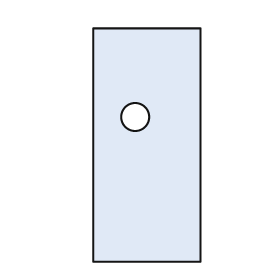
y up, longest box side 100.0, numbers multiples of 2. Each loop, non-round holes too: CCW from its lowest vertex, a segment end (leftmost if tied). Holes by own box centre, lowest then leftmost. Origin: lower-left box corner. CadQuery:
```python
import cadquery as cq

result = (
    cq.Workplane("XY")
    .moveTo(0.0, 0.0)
    .lineTo(46.0, 0.0)
    .lineTo(46.0, 100.0)
    .lineTo(0.0, 100.0)
    .close()
    .moveTo(18.0, 62.0)
    .circle(6.0)
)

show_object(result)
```